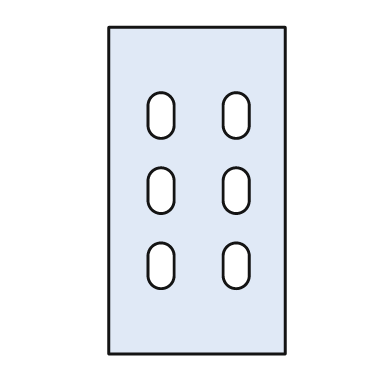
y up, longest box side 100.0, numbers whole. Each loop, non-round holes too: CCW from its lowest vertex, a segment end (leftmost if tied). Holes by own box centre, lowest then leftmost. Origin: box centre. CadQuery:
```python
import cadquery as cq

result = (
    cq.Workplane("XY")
    .moveTo(-27.0, -50.0)
    .lineTo(27.0, -50.0)
    .lineTo(27.0, 50.0)
    .lineTo(-27.0, 50.0)
    .close()
    .moveTo(-15.0, -26.0)
    .threePointArc((-11.0, -30.0), (-7.0, -26.0))
    .lineTo(-7.0, -20.0)
    .threePointArc((-11.0, -16.0), (-15.0, -20.0))
    .close()
    .moveTo(8.0, -26.0)
    .threePointArc((12.0, -30.0), (16.0, -26.0))
    .lineTo(16.0, -20.0)
    .threePointArc((12.0, -16.0), (8.0, -20.0))
    .close()
    .moveTo(-15.0, -3.0)
    .threePointArc((-11.0, -7.0), (-7.0, -3.0))
    .lineTo(-7.0, 3.0)
    .threePointArc((-11.0, 7.0), (-15.0, 3.0))
    .close()
    .moveTo(8.0, -3.0)
    .threePointArc((12.0, -7.0), (16.0, -3.0))
    .lineTo(16.0, 3.0)
    .threePointArc((12.0, 7.0), (8.0, 3.0))
    .close()
    .moveTo(-15.0, 20.0)
    .threePointArc((-11.0, 16.0), (-7.0, 20.0))
    .lineTo(-7.0, 26.0)
    .threePointArc((-11.0, 30.0), (-15.0, 26.0))
    .close()
    .moveTo(8.0, 20.0)
    .threePointArc((12.0, 16.0), (16.0, 20.0))
    .lineTo(16.0, 26.0)
    .threePointArc((12.0, 30.0), (8.0, 26.0))
    .close()
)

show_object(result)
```